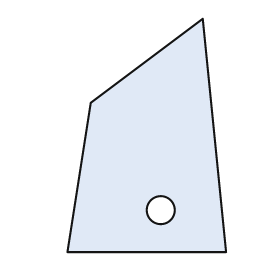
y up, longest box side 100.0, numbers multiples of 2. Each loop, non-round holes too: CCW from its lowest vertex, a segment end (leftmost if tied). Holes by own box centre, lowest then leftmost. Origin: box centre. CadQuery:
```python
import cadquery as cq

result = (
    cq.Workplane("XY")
    .moveTo(-34.0, -50.0)
    .lineTo(34.0, -50.0)
    .lineTo(24.0, 50.0)
    .lineTo(-24.0, 14.0)
    .close()
    .moveTo(6.0, -32.0)
    .circle(6.0)
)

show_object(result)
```